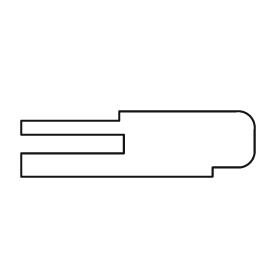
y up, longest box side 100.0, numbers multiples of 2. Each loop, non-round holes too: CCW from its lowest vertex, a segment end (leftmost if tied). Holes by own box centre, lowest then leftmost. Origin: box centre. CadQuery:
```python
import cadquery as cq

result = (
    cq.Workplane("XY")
    .moveTo(-50.0, -14.0)
    .lineTo(32.0, -14.0)
    .lineTo(32.0, -10.0)
    .lineTo(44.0, -10.0)
    .threePointArc((48.0, -8.0), (50.0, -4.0))
    .lineTo(50.0, 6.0)
    .threePointArc((48.0, 12.0), (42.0, 14.0))
    .lineTo(-8.0, 14.0)
    .lineTo(-8.0, 10.0)
    .lineTo(-50.0, 10.0)
    .lineTo(-50.0, 4.0)
    .lineTo(-6.0, 4.0)
    .lineTo(-6.0, -4.0)
    .lineTo(-50.0, -4.0)
    .close()
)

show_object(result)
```